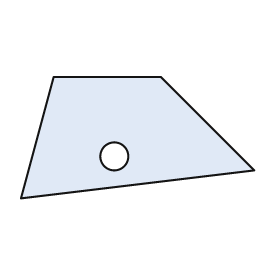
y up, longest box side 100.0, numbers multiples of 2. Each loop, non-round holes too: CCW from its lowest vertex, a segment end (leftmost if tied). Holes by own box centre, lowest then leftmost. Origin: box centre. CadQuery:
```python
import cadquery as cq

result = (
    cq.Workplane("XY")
    .moveTo(-50.0, -26.0)
    .lineTo(50.0, -14.0)
    .lineTo(10.0, 26.0)
    .lineTo(-36.0, 26.0)
    .close()
    .moveTo(-10.0, -8.0)
    .circle(6.0)
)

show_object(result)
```